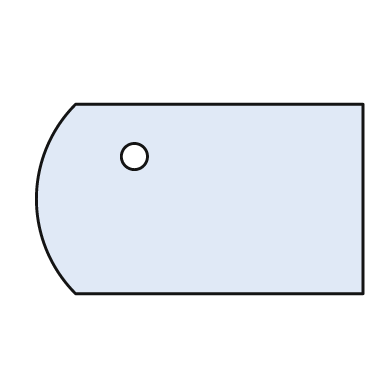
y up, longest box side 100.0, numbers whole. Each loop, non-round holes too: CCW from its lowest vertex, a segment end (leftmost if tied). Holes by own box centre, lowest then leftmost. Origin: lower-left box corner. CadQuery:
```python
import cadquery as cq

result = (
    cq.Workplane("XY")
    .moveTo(12.0, 0.0)
    .lineTo(100.0, 0.0)
    .lineTo(100.0, 58.0)
    .lineTo(12.0, 58.0)
    .threePointArc((0.0, 29.0), (12.0, 0.0))
    .close()
    .moveTo(30.0, 42.0)
    .circle(4.0)
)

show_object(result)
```